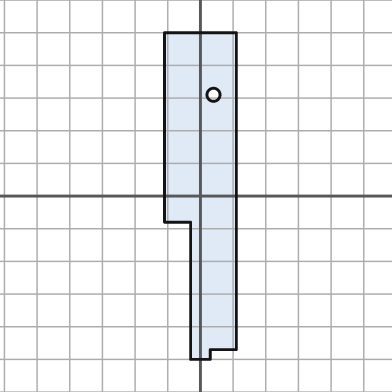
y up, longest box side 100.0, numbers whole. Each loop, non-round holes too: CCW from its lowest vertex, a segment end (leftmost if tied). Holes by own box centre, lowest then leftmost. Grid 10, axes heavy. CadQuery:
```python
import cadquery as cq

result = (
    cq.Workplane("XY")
    .moveTo(-3.0, -50.0)
    .lineTo(3.0, -50.0)
    .lineTo(3.0, -47.0)
    .lineTo(11.0, -47.0)
    .lineTo(11.0, 50.0)
    .lineTo(-11.0, 50.0)
    .lineTo(-11.0, -8.0)
    .lineTo(-3.0, -8.0)
    .close()
    .moveTo(4.0, 31.0)
    .circle(2.0)
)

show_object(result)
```